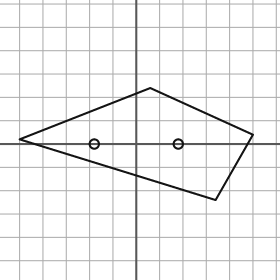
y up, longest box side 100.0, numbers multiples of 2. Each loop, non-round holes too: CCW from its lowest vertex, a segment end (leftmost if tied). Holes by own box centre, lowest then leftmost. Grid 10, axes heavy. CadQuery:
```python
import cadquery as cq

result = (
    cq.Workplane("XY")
    .moveTo(34.0, -24.0)
    .lineTo(50.0, 4.0)
    .lineTo(6.0, 24.0)
    .lineTo(-50.0, 2.0)
    .close()
    .moveTo(-18.0, 0.0)
    .circle(2.0)
    .moveTo(18.0, 0.0)
    .circle(2.0)
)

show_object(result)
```